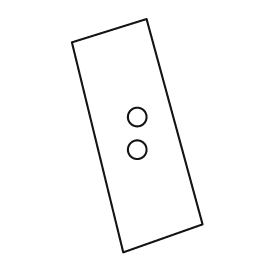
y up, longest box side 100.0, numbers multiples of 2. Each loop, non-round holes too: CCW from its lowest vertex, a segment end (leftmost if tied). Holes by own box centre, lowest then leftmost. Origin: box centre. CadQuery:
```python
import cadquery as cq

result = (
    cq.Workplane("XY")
    .moveTo(-6.0, -50.0)
    .lineTo(28.0, -38.0)
    .lineTo(4.0, 50.0)
    .lineTo(-28.0, 40.0)
    .close()
    .moveTo(0.0, -6.0)
    .circle(4.0)
    .moveTo(0.0, 8.0)
    .circle(4.0)
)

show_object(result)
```